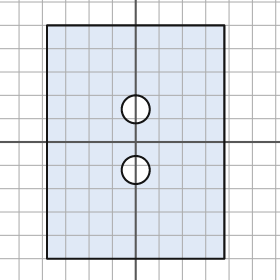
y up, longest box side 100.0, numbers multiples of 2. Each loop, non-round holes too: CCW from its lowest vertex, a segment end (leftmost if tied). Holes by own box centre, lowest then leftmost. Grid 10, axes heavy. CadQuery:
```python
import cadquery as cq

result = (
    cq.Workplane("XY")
    .moveTo(-38.0, -50.0)
    .lineTo(38.0, -50.0)
    .lineTo(38.0, 50.0)
    .lineTo(-38.0, 50.0)
    .close()
    .moveTo(0.0, -12.0)
    .circle(6.0)
    .moveTo(0.0, 14.0)
    .circle(6.0)
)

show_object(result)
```